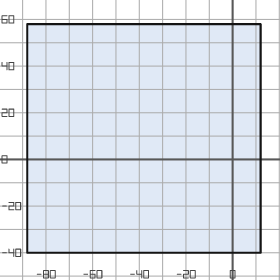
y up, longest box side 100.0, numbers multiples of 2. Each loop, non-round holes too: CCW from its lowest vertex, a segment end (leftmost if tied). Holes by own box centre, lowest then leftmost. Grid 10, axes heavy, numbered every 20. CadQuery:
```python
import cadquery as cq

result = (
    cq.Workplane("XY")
    .moveTo(-88.0, -40.0)
    .lineTo(12.0, -40.0)
    .lineTo(12.0, 58.0)
    .lineTo(-88.0, 58.0)
    .close()
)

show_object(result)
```